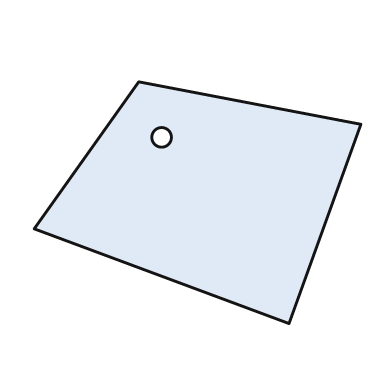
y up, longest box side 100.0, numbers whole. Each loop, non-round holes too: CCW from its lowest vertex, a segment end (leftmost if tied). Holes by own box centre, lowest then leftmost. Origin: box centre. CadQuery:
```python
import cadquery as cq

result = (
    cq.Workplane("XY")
    .moveTo(28.0, -37.0)
    .lineTo(50.0, 24.0)
    .lineTo(-18.0, 37.0)
    .lineTo(-50.0, -8.0)
    .close()
    .moveTo(-11.0, 20.0)
    .circle(3.0)
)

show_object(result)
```